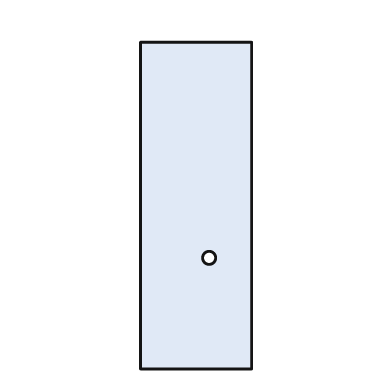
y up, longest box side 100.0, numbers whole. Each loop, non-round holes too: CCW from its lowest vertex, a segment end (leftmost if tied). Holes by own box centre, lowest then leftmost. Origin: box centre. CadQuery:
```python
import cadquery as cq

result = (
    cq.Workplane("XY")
    .moveTo(-17.0, -50.0)
    .lineTo(17.0, -50.0)
    .lineTo(17.0, 50.0)
    .lineTo(-17.0, 50.0)
    .close()
    .moveTo(4.0, -16.0)
    .circle(2.0)
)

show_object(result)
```